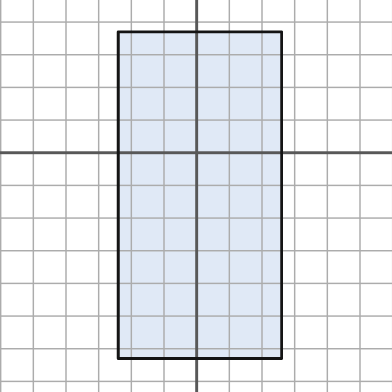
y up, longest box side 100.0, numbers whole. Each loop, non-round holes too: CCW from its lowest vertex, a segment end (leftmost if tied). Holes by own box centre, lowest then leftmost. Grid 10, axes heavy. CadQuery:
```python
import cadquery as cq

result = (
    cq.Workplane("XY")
    .moveTo(-24.0, -63.0)
    .lineTo(26.0, -63.0)
    .lineTo(26.0, 37.0)
    .lineTo(-24.0, 37.0)
    .close()
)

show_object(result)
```